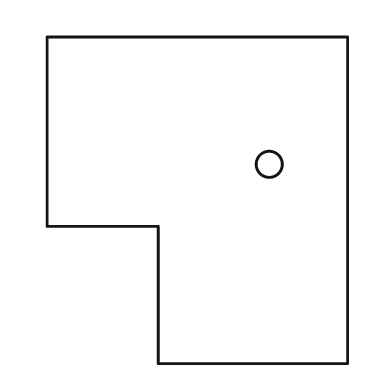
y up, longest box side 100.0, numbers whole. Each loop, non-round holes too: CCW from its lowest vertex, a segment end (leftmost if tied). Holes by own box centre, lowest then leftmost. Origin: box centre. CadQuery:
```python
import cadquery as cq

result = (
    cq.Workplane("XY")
    .moveTo(-12.0, -50.0)
    .lineTo(46.0, -50.0)
    .lineTo(46.0, 50.0)
    .lineTo(-46.0, 50.0)
    .lineTo(-46.0, -8.0)
    .lineTo(-12.0, -8.0)
    .close()
    .moveTo(22.0, 11.0)
    .circle(4.0)
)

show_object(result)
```